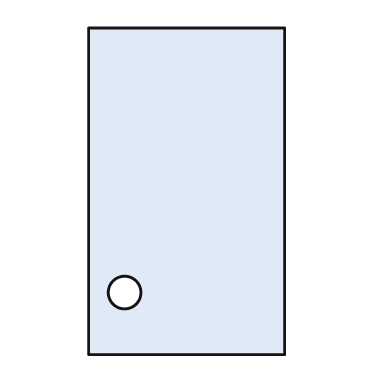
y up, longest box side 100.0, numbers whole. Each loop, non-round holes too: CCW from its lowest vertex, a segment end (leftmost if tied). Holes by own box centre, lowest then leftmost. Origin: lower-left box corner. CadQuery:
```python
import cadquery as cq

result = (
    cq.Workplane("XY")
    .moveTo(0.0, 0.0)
    .lineTo(60.0, 0.0)
    .lineTo(60.0, 100.0)
    .lineTo(0.0, 100.0)
    .close()
    .moveTo(11.0, 19.0)
    .circle(5.0)
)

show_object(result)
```